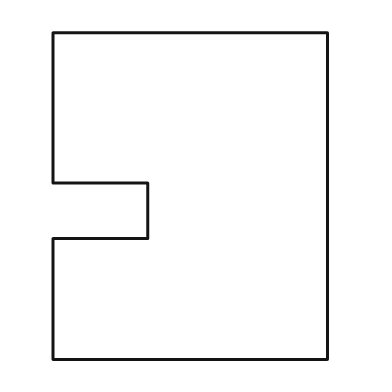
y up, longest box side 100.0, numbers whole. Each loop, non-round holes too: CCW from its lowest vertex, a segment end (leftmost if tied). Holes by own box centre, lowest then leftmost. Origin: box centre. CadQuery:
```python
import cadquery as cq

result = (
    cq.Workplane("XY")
    .moveTo(-42.0, -50.0)
    .lineTo(42.0, -50.0)
    .lineTo(42.0, 50.0)
    .lineTo(-42.0, 50.0)
    .lineTo(-42.0, 4.0)
    .lineTo(-13.0, 4.0)
    .lineTo(-13.0, -13.0)
    .lineTo(-42.0, -13.0)
    .close()
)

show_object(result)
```